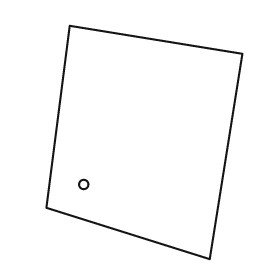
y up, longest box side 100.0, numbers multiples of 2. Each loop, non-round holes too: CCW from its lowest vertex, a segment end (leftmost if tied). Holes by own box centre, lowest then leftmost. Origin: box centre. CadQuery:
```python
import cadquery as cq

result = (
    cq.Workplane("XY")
    .moveTo(28.0, -50.0)
    .lineTo(42.0, 38.0)
    .lineTo(-32.0, 50.0)
    .lineTo(-42.0, -28.0)
    .close()
    .moveTo(-26.0, -18.0)
    .circle(2.0)
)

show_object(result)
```